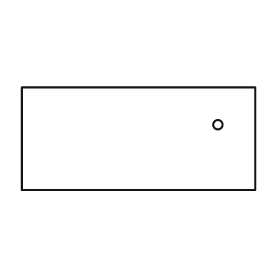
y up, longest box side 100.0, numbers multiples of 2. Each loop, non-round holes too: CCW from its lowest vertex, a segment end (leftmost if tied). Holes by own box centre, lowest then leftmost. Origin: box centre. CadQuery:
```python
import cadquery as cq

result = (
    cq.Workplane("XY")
    .moveTo(-50.0, -22.0)
    .lineTo(50.0, -22.0)
    .lineTo(50.0, 22.0)
    .lineTo(-50.0, 22.0)
    .close()
    .moveTo(34.0, 6.0)
    .circle(2.0)
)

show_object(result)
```